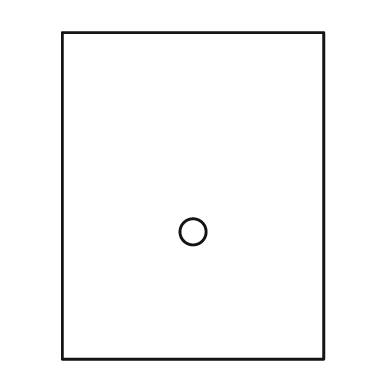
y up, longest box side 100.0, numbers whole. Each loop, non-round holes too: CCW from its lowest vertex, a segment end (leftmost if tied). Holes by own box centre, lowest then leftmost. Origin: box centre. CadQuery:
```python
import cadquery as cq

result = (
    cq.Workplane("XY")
    .moveTo(-40.0, -50.0)
    .lineTo(40.0, -50.0)
    .lineTo(40.0, 50.0)
    .lineTo(-40.0, 50.0)
    .close()
    .moveTo(0.0, -11.0)
    .circle(4.0)
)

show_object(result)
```